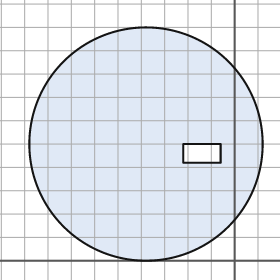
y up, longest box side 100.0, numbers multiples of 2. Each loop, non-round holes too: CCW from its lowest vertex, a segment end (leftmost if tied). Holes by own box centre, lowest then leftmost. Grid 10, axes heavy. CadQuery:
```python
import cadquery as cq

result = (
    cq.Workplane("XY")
    .moveTo(-38.0, 50.0)
    .circle(50.0)
    .moveTo(-22.0, 42.0)
    .lineTo(-6.0, 42.0)
    .lineTo(-6.0, 50.0)
    .lineTo(-22.0, 50.0)
    .close()
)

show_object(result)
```